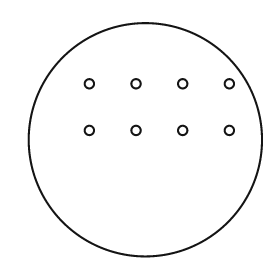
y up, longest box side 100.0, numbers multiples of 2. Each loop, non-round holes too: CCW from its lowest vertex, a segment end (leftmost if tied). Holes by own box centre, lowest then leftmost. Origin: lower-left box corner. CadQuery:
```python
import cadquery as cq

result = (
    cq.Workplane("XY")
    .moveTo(50.0, 50.0)
    .circle(50.0)
    .moveTo(26.0, 54.0)
    .circle(2.0)
    .moveTo(46.0, 54.0)
    .circle(2.0)
    .moveTo(66.0, 54.0)
    .circle(2.0)
    .moveTo(86.0, 54.0)
    .circle(2.0)
    .moveTo(26.0, 74.0)
    .circle(2.0)
    .moveTo(46.0, 74.0)
    .circle(2.0)
    .moveTo(66.0, 74.0)
    .circle(2.0)
    .moveTo(86.0, 74.0)
    .circle(2.0)
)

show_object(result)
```